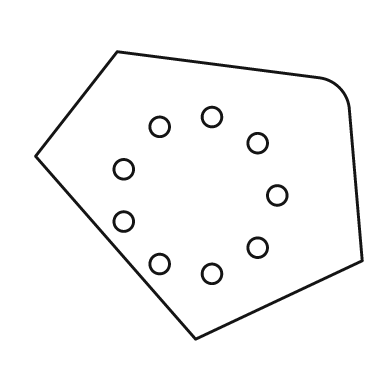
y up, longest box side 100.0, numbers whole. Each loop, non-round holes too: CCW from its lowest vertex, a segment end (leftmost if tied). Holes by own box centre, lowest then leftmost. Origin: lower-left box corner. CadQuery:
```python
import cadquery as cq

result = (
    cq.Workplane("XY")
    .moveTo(49.0, 0.0)
    .lineTo(100.0, 24.0)
    .lineTo(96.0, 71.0)
    .threePointArc((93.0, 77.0), (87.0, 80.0))
    .lineTo(25.0, 88.0)
    .lineTo(0.0, 56.0)
    .close()
    .moveTo(54.0, 20.0)
    .circle(3.0)
    .moveTo(38.0, 23.0)
    .circle(3.0)
    .moveTo(68.0, 28.0)
    .circle(3.0)
    .moveTo(27.0, 36.0)
    .circle(3.0)
    .moveTo(74.0, 44.0)
    .circle(3.0)
    .moveTo(27.0, 52.0)
    .circle(3.0)
    .moveTo(68.0, 60.0)
    .circle(3.0)
    .moveTo(38.0, 65.0)
    .circle(3.0)
    .moveTo(54.0, 68.0)
    .circle(3.0)
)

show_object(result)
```